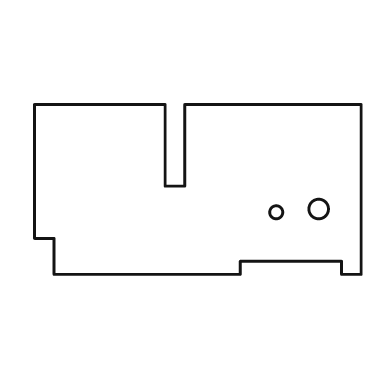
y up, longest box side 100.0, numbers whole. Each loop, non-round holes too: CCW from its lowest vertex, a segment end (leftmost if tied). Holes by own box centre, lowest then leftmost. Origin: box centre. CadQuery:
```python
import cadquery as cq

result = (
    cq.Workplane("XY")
    .moveTo(-44.0, -26.0)
    .lineTo(13.0, -26.0)
    .lineTo(13.0, -22.0)
    .lineTo(44.0, -22.0)
    .lineTo(44.0, -26.0)
    .lineTo(50.0, -26.0)
    .lineTo(50.0, 26.0)
    .lineTo(-4.0, 26.0)
    .lineTo(-4.0, 1.0)
    .lineTo(-10.0, 1.0)
    .lineTo(-10.0, 26.0)
    .lineTo(-50.0, 26.0)
    .lineTo(-50.0, -15.0)
    .lineTo(-44.0, -15.0)
    .close()
    .moveTo(24.0, -7.0)
    .circle(2.0)
    .moveTo(37.0, -6.0)
    .circle(3.0)
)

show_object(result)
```